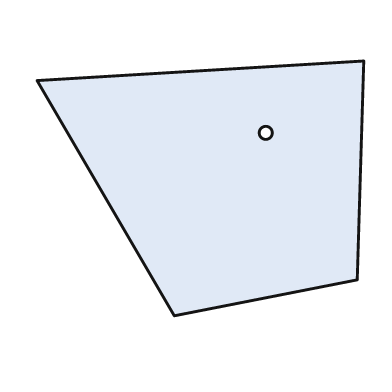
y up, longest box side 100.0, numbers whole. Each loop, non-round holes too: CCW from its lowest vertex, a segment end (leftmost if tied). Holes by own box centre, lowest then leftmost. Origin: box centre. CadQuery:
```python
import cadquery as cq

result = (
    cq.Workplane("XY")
    .moveTo(-8.0, -39.0)
    .lineTo(48.0, -28.0)
    .lineTo(50.0, 39.0)
    .lineTo(-50.0, 33.0)
    .close()
    .moveTo(20.0, 17.0)
    .circle(2.0)
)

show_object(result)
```